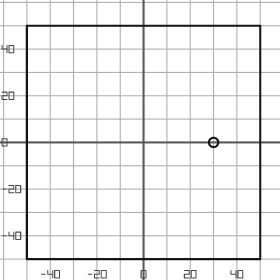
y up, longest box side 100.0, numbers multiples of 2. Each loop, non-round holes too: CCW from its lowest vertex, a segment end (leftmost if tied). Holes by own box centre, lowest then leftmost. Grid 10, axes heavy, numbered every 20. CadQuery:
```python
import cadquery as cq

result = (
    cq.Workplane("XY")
    .moveTo(-50.0, -50.0)
    .lineTo(50.0, -50.0)
    .lineTo(50.0, 50.0)
    .lineTo(-50.0, 50.0)
    .close()
    .moveTo(30.0, 0.0)
    .circle(2.0)
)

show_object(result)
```